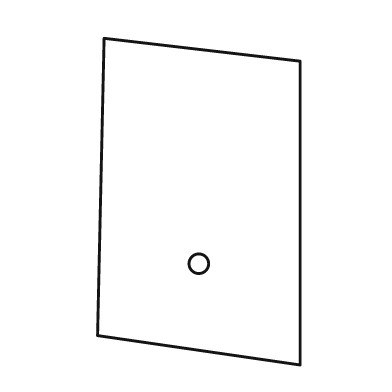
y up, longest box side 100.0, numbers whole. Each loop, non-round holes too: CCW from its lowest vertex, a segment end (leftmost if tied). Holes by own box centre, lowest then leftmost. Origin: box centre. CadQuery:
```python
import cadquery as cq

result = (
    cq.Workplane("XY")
    .moveTo(31.0, -50.0)
    .lineTo(31.0, 43.0)
    .lineTo(-29.0, 50.0)
    .lineTo(-31.0, -41.0)
    .close()
    .moveTo(0.0, -19.0)
    .circle(3.0)
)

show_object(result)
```